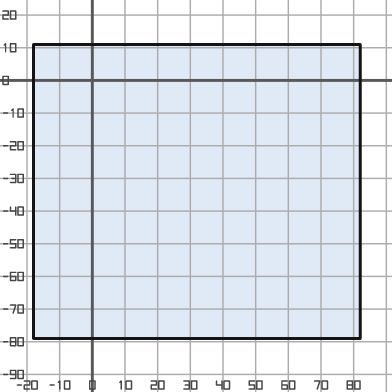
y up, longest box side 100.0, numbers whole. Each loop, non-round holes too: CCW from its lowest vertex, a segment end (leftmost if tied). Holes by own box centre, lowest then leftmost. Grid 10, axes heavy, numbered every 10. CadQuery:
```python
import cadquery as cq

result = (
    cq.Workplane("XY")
    .moveTo(-18.0, -79.0)
    .lineTo(82.0, -79.0)
    .lineTo(82.0, 11.0)
    .lineTo(-18.0, 11.0)
    .close()
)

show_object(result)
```